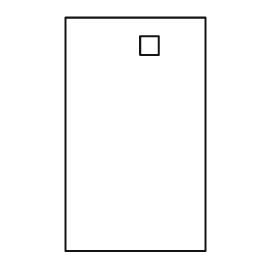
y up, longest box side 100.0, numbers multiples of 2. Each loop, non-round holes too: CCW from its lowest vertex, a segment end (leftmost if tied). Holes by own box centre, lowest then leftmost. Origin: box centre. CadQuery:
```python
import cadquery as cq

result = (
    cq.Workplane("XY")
    .moveTo(-30.0, -50.0)
    .lineTo(30.0, -50.0)
    .lineTo(30.0, 50.0)
    .lineTo(-30.0, 50.0)
    .close()
    .moveTo(2.0, 34.0)
    .lineTo(10.0, 34.0)
    .lineTo(10.0, 42.0)
    .lineTo(2.0, 42.0)
    .close()
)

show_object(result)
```